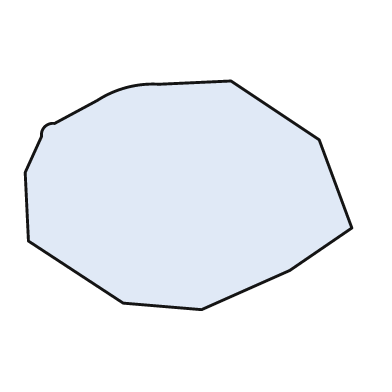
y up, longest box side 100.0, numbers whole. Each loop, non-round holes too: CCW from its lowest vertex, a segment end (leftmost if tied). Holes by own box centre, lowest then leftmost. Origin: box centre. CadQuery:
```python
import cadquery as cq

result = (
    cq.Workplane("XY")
    .moveTo(4.0, -35.0)
    .lineTo(31.0, -23.0)
    .lineTo(50.0, -10.0)
    .lineTo(40.0, 17.0)
    .lineTo(13.0, 35.0)
    .lineTo(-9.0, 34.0)
    .threePointArc((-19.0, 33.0), (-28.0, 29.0))
    .lineTo(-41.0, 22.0)
    .threePointArc((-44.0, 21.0), (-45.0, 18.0))
    .lineTo(-50.0, 7.0)
    .lineTo(-49.0, -14.0)
    .lineTo(-20.0, -33.0)
    .close()
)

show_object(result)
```